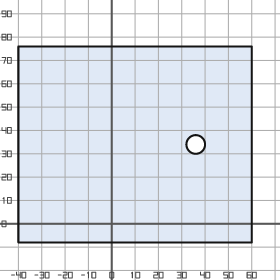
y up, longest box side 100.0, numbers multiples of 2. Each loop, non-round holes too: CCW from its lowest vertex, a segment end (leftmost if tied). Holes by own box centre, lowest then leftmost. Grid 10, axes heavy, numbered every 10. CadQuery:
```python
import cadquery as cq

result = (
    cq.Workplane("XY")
    .moveTo(-40.0, -8.0)
    .lineTo(60.0, -8.0)
    .lineTo(60.0, 76.0)
    .lineTo(-40.0, 76.0)
    .close()
    .moveTo(36.0, 34.0)
    .circle(4.0)
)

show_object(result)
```